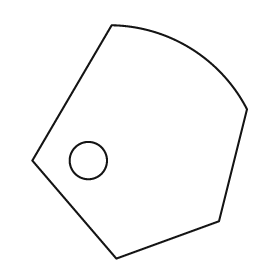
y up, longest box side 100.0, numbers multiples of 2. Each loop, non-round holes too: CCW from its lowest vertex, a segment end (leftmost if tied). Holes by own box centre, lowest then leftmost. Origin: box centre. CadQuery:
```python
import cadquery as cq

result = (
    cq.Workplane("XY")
    .moveTo(-10.0, -50.0)
    .lineTo(34.0, -34.0)
    .lineTo(46.0, 14.0)
    .threePointArc((22.0, 40.0), (-12.0, 50.0))
    .lineTo(-46.0, -8.0)
    .close()
    .moveTo(-22.0, -8.0)
    .circle(8.0)
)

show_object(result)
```